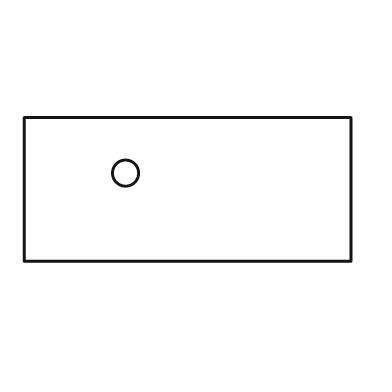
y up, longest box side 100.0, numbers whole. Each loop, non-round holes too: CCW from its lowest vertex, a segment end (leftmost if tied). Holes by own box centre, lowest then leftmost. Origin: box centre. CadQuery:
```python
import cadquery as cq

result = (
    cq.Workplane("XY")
    .moveTo(-50.0, -22.0)
    .lineTo(50.0, -22.0)
    .lineTo(50.0, 22.0)
    .lineTo(-50.0, 22.0)
    .close()
    .moveTo(-19.0, 5.0)
    .circle(4.0)
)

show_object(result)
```